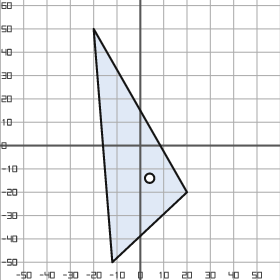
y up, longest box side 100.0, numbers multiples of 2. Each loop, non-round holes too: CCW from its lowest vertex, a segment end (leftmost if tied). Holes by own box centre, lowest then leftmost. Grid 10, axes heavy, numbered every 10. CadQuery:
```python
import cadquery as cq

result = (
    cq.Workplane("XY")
    .moveTo(-12.0, -50.0)
    .lineTo(20.0, -20.0)
    .lineTo(-20.0, 50.0)
    .close()
    .moveTo(4.0, -14.0)
    .circle(2.0)
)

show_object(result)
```